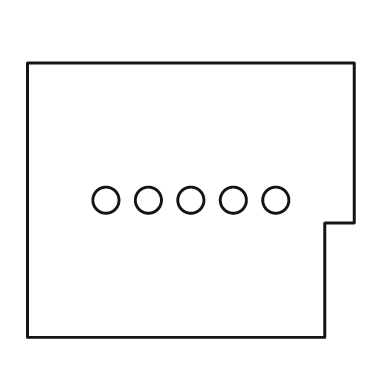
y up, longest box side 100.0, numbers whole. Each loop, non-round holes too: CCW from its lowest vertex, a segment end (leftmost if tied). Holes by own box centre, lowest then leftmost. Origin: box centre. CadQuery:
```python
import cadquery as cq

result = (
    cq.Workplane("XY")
    .moveTo(-50.0, -42.0)
    .lineTo(41.0, -42.0)
    .lineTo(41.0, -7.0)
    .lineTo(50.0, -7.0)
    .lineTo(50.0, 42.0)
    .lineTo(-50.0, 42.0)
    .close()
    .moveTo(-26.0, 0.0)
    .circle(4.0)
    .moveTo(-13.0, 0.0)
    .circle(4.0)
    .moveTo(0.0, 0.0)
    .circle(4.0)
    .moveTo(13.0, 0.0)
    .circle(4.0)
    .moveTo(26.0, 0.0)
    .circle(4.0)
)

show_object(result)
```